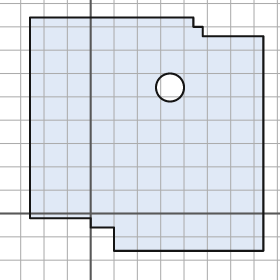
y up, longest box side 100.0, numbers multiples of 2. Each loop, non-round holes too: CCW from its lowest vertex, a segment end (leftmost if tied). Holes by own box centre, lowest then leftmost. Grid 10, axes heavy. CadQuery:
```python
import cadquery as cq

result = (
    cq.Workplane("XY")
    .moveTo(10.0, -16.0)
    .lineTo(74.0, -16.0)
    .lineTo(74.0, 76.0)
    .lineTo(48.0, 76.0)
    .lineTo(48.0, 80.0)
    .lineTo(44.0, 80.0)
    .lineTo(44.0, 84.0)
    .lineTo(-26.0, 84.0)
    .lineTo(-26.0, -2.0)
    .lineTo(0.0, -2.0)
    .lineTo(0.0, -6.0)
    .lineTo(10.0, -6.0)
    .close()
    .moveTo(34.0, 54.0)
    .circle(6.0)
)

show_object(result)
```